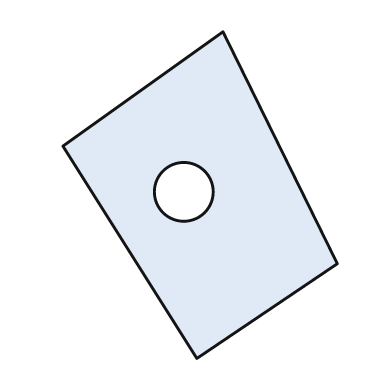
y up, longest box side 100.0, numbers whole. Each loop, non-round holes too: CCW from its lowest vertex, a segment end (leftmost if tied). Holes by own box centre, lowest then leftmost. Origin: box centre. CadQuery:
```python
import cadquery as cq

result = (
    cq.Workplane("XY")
    .moveTo(-1.0, -50.0)
    .lineTo(42.0, -21.0)
    .lineTo(7.0, 50.0)
    .lineTo(-42.0, 15.0)
    .close()
    .moveTo(-5.0, 1.0)
    .circle(9.0)
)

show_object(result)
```